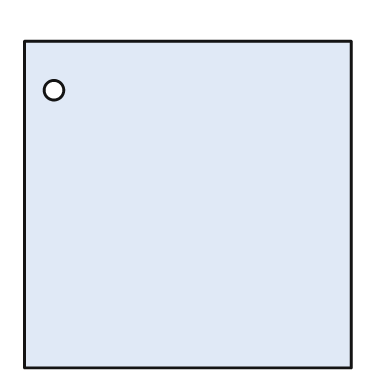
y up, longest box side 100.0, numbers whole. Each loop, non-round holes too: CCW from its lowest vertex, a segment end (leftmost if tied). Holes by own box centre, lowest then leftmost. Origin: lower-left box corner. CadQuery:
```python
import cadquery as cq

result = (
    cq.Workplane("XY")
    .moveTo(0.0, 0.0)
    .lineTo(100.0, 0.0)
    .lineTo(100.0, 100.0)
    .lineTo(0.0, 100.0)
    .close()
    .moveTo(9.0, 85.0)
    .circle(3.0)
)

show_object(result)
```